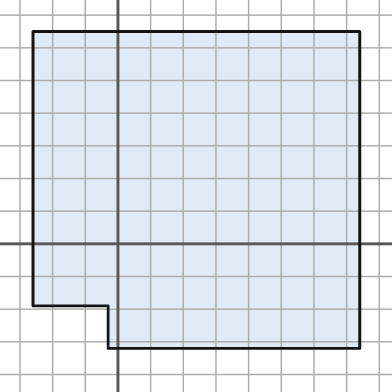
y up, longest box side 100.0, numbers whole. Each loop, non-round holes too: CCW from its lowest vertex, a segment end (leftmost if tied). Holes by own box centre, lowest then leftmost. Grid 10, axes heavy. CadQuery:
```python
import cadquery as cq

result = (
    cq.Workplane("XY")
    .moveTo(-3.0, -32.0)
    .lineTo(74.0, -32.0)
    .lineTo(74.0, 65.0)
    .lineTo(-26.0, 65.0)
    .lineTo(-26.0, -19.0)
    .lineTo(-3.0, -19.0)
    .close()
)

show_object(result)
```